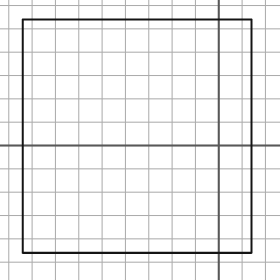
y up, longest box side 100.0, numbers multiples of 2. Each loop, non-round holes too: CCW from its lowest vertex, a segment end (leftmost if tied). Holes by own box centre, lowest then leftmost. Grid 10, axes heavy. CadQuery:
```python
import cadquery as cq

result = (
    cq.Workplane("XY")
    .moveTo(-84.0, -46.0)
    .lineTo(14.0, -46.0)
    .lineTo(14.0, 54.0)
    .lineTo(-84.0, 54.0)
    .close()
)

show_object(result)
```